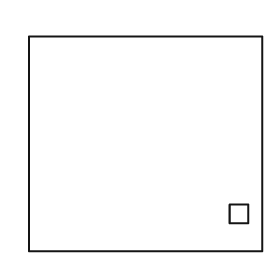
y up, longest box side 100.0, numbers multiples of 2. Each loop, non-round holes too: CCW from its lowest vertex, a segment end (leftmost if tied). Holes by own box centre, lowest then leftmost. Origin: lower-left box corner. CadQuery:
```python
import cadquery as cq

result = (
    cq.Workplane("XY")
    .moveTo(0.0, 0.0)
    .lineTo(100.0, 0.0)
    .lineTo(100.0, 92.0)
    .lineTo(0.0, 92.0)
    .close()
    .moveTo(86.0, 12.0)
    .lineTo(94.0, 12.0)
    .lineTo(94.0, 20.0)
    .lineTo(86.0, 20.0)
    .close()
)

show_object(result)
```